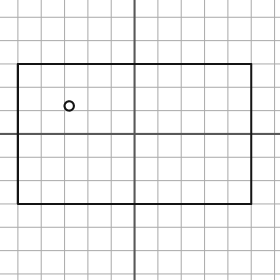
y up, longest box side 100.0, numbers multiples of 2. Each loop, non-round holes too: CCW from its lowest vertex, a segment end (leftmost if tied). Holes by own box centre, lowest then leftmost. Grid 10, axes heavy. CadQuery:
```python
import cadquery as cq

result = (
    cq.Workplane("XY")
    .moveTo(-50.0, -30.0)
    .lineTo(50.0, -30.0)
    .lineTo(50.0, 30.0)
    .lineTo(-50.0, 30.0)
    .close()
    .moveTo(-28.0, 12.0)
    .circle(2.0)
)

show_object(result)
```